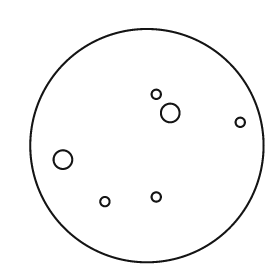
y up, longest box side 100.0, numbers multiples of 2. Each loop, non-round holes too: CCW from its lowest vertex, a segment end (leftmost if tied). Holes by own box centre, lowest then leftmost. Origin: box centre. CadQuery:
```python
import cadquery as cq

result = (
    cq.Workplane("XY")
    .moveTo(0.0, 0.0)
    .circle(50.0)
    .moveTo(-18.0, -24.0)
    .circle(2.0)
    .moveTo(4.0, -22.0)
    .circle(2.0)
    .moveTo(-36.0, -6.0)
    .circle(4.0)
    .moveTo(40.0, 10.0)
    .circle(2.0)
    .moveTo(10.0, 14.0)
    .circle(4.0)
    .moveTo(4.0, 22.0)
    .circle(2.0)
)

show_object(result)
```